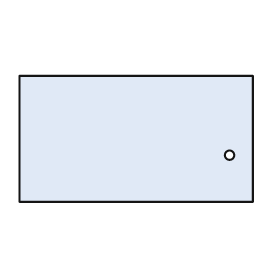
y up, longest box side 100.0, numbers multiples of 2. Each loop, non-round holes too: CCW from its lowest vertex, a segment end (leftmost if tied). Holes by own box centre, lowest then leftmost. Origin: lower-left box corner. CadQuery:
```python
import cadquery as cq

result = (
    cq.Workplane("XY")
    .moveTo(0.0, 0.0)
    .lineTo(100.0, 0.0)
    .lineTo(100.0, 54.0)
    .lineTo(0.0, 54.0)
    .close()
    .moveTo(90.0, 20.0)
    .circle(2.0)
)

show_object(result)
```